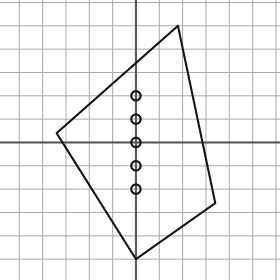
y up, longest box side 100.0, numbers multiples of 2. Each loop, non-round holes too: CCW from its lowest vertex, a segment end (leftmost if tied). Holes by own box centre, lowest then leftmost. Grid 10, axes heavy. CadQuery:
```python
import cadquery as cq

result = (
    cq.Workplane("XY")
    .moveTo(0.0, -50.0)
    .lineTo(34.0, -26.0)
    .lineTo(18.0, 50.0)
    .lineTo(-34.0, 4.0)
    .close()
    .moveTo(0.0, -20.0)
    .circle(2.0)
    .moveTo(0.0, -10.0)
    .circle(2.0)
    .moveTo(0.0, 0.0)
    .circle(2.0)
    .moveTo(0.0, 10.0)
    .circle(2.0)
    .moveTo(0.0, 20.0)
    .circle(2.0)
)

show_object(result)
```